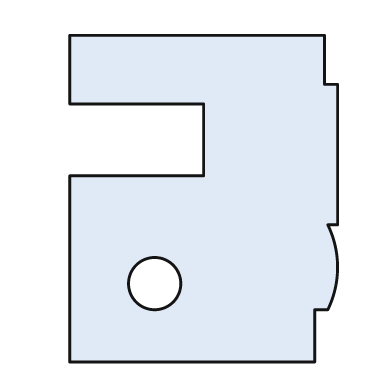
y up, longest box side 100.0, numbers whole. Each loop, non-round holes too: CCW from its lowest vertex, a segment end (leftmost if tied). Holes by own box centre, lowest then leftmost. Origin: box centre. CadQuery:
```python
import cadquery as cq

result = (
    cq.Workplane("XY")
    .moveTo(-41.0, -50.0)
    .lineTo(34.0, -50.0)
    .lineTo(34.0, -34.0)
    .lineTo(38.0, -34.0)
    .threePointArc((41.0, -21.0), (38.0, -8.0))
    .lineTo(41.0, -8.0)
    .lineTo(41.0, 35.0)
    .lineTo(37.0, 35.0)
    .lineTo(37.0, 50.0)
    .lineTo(-41.0, 50.0)
    .lineTo(-41.0, 29.0)
    .lineTo(0.0, 29.0)
    .lineTo(0.0, 7.0)
    .lineTo(-41.0, 7.0)
    .close()
    .moveTo(-15.0, -26.0)
    .circle(8.0)
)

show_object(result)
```